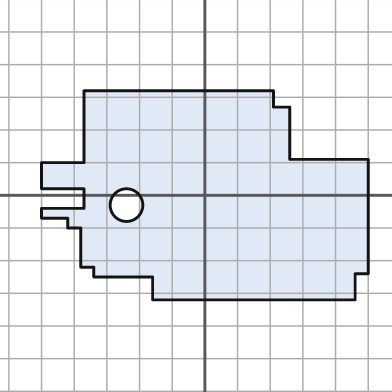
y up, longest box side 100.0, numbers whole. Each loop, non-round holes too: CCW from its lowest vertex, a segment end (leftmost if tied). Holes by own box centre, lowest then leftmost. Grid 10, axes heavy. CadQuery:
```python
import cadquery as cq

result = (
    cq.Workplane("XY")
    .moveTo(-16.0, -32.0)
    .lineTo(46.0, -32.0)
    .lineTo(46.0, -24.0)
    .lineTo(50.0, -24.0)
    .lineTo(50.0, 11.0)
    .lineTo(26.0, 11.0)
    .lineTo(26.0, 27.0)
    .lineTo(21.0, 27.0)
    .lineTo(21.0, 32.0)
    .lineTo(-37.0, 32.0)
    .lineTo(-37.0, 10.0)
    .lineTo(-50.0, 10.0)
    .lineTo(-50.0, 2.0)
    .lineTo(-37.0, 2.0)
    .lineTo(-37.0, -4.0)
    .lineTo(-50.0, -4.0)
    .lineTo(-50.0, -7.0)
    .lineTo(-42.0, -7.0)
    .lineTo(-42.0, -10.0)
    .lineTo(-38.0, -10.0)
    .lineTo(-38.0, -22.0)
    .lineTo(-34.0, -22.0)
    .lineTo(-34.0, -25.0)
    .lineTo(-16.0, -25.0)
    .close()
    .moveTo(-24.0, -3.0)
    .circle(5.0)
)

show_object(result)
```